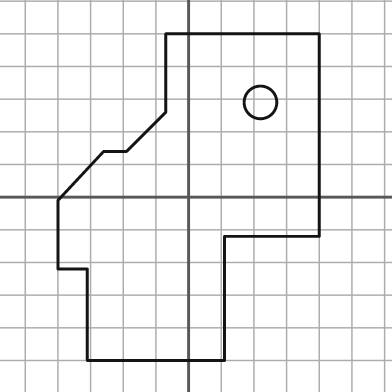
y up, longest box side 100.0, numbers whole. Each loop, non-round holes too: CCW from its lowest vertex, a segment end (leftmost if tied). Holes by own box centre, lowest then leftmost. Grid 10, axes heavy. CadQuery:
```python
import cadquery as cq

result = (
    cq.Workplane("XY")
    .moveTo(-31.0, -50.0)
    .lineTo(11.0, -50.0)
    .lineTo(11.0, -12.0)
    .lineTo(40.0, -12.0)
    .lineTo(40.0, 50.0)
    .lineTo(-7.0, 50.0)
    .lineTo(-7.0, 26.0)
    .lineTo(-19.0, 14.0)
    .lineTo(-26.0, 14.0)
    .lineTo(-40.0, -1.0)
    .lineTo(-40.0, -22.0)
    .lineTo(-31.0, -22.0)
    .close()
    .moveTo(22.0, 29.0)
    .circle(5.0)
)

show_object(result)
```